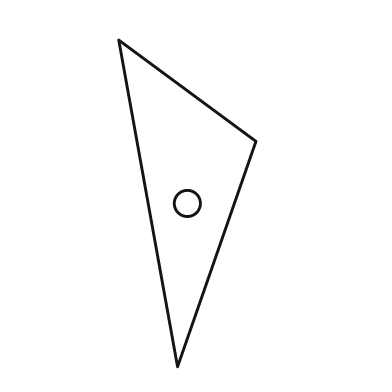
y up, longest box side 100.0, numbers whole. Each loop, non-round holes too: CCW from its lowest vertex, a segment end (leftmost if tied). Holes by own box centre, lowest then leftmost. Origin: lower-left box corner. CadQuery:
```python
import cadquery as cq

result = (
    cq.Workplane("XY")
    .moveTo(18.0, 0.0)
    .lineTo(42.0, 69.0)
    .lineTo(0.0, 100.0)
    .close()
    .moveTo(21.0, 50.0)
    .circle(4.0)
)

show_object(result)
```